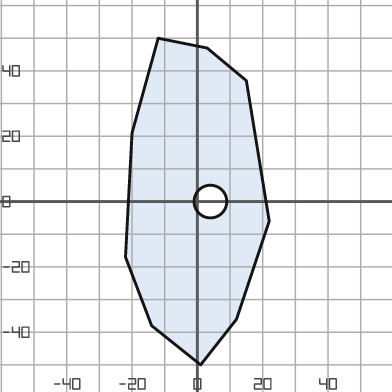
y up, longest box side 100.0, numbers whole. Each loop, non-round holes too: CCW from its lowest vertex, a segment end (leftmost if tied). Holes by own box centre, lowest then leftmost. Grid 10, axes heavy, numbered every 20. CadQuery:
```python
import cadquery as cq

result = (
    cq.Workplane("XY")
    .moveTo(1.0, -50.0)
    .lineTo(12.0, -36.0)
    .lineTo(22.0, -6.0)
    .lineTo(15.0, 37.0)
    .lineTo(3.0, 47.0)
    .lineTo(-12.0, 50.0)
    .lineTo(-20.0, 21.0)
    .lineTo(-22.0, -17.0)
    .lineTo(-14.0, -38.0)
    .close()
    .moveTo(4.0, 0.0)
    .circle(5.0)
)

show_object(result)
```